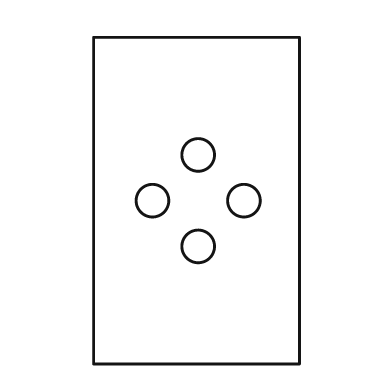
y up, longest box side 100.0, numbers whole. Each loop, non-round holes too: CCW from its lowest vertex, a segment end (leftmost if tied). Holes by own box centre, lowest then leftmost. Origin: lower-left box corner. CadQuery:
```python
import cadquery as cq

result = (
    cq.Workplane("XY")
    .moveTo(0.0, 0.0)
    .lineTo(63.0, 0.0)
    .lineTo(63.0, 100.0)
    .lineTo(0.0, 100.0)
    .close()
    .moveTo(32.0, 36.0)
    .circle(5.0)
    .moveTo(18.0, 50.0)
    .circle(5.0)
    .moveTo(46.0, 50.0)
    .circle(5.0)
    .moveTo(32.0, 64.0)
    .circle(5.0)
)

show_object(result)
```